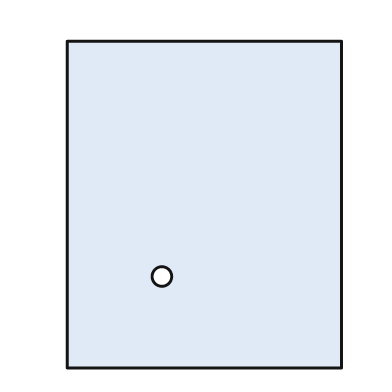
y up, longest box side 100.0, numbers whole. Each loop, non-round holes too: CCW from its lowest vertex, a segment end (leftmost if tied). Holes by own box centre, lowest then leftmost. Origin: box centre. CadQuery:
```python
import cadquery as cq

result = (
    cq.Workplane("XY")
    .moveTo(-42.0, -50.0)
    .lineTo(42.0, -50.0)
    .lineTo(42.0, 50.0)
    .lineTo(-42.0, 50.0)
    .close()
    .moveTo(-13.0, -22.0)
    .circle(3.0)
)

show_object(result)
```